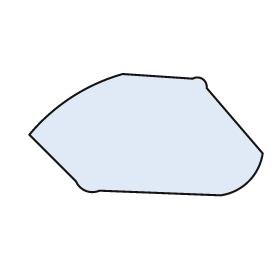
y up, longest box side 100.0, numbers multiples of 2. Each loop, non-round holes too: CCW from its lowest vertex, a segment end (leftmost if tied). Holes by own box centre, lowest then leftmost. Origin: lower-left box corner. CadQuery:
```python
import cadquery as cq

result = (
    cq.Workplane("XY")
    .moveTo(82.0, 0.0)
    .threePointArc((94.0, 6.0), (100.0, 18.0))
    .lineTo(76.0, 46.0)
    .threePointArc((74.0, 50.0), (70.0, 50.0))
    .lineTo(40.0, 52.0)
    .threePointArc((18.0, 42.0), (0.0, 26.0))
    .lineTo(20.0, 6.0)
    .threePointArc((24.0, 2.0), (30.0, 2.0))
    .close()
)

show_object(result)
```